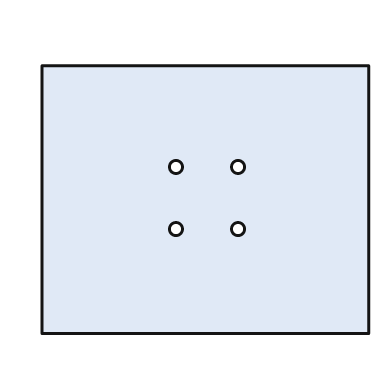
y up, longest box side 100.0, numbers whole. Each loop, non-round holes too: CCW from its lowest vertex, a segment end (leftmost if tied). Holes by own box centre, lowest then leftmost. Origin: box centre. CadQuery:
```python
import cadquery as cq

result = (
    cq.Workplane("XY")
    .moveTo(-50.0, -41.0)
    .lineTo(50.0, -41.0)
    .lineTo(50.0, 41.0)
    .lineTo(-50.0, 41.0)
    .close()
    .moveTo(-9.0, -9.0)
    .circle(2.0)
    .moveTo(10.0, -9.0)
    .circle(2.0)
    .moveTo(-9.0, 10.0)
    .circle(2.0)
    .moveTo(10.0, 10.0)
    .circle(2.0)
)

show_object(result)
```